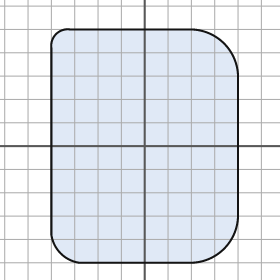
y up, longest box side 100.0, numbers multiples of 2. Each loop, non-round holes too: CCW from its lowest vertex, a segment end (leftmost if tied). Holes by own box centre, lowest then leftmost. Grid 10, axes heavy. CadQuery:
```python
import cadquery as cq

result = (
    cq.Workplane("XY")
    .moveTo(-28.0, -50.0)
    .lineTo(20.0, -50.0)
    .threePointArc((34.0, -44.0), (40.0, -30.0))
    .lineTo(40.0, 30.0)
    .threePointArc((34.0, 44.0), (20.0, 50.0))
    .lineTo(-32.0, 50.0)
    .threePointArc((-38.0, 48.0), (-40.0, 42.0))
    .lineTo(-40.0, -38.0)
    .threePointArc((-36.0, -46.0), (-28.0, -50.0))
    .close()
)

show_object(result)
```